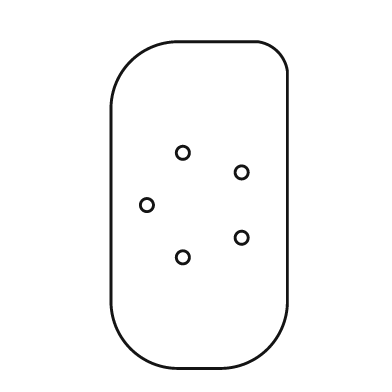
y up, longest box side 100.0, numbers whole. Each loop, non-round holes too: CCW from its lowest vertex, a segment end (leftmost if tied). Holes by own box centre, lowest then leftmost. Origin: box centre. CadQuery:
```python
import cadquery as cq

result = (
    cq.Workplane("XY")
    .moveTo(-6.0, -50.0)
    .lineTo(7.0, -50.0)
    .threePointArc((21.0, -44.0), (27.0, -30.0))
    .lineTo(27.0, 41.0)
    .threePointArc((24.0, 47.0), (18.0, 50.0))
    .lineTo(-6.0, 50.0)
    .threePointArc((-21.0, 44.0), (-27.0, 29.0))
    .lineTo(-27.0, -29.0)
    .threePointArc((-21.0, -44.0), (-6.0, -50.0))
    .close()
    .moveTo(-5.0, -16.0)
    .circle(2.0)
    .moveTo(13.0, -10.0)
    .circle(2.0)
    .moveTo(-16.0, 0.0)
    .circle(2.0)
    .moveTo(13.0, 10.0)
    .circle(2.0)
    .moveTo(-5.0, 16.0)
    .circle(2.0)
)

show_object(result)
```